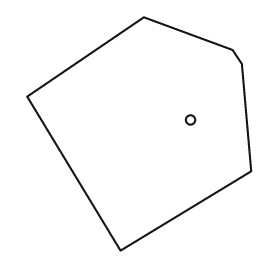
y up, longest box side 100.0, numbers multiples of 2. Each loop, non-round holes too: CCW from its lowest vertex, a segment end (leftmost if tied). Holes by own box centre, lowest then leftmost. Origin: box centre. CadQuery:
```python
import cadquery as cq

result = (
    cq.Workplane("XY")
    .moveTo(-8.0, -50.0)
    .lineTo(48.0, -16.0)
    .lineTo(44.0, 30.0)
    .lineTo(40.0, 36.0)
    .lineTo(2.0, 50.0)
    .lineTo(-48.0, 16.0)
    .close()
    .moveTo(22.0, 6.0)
    .circle(2.0)
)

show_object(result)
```